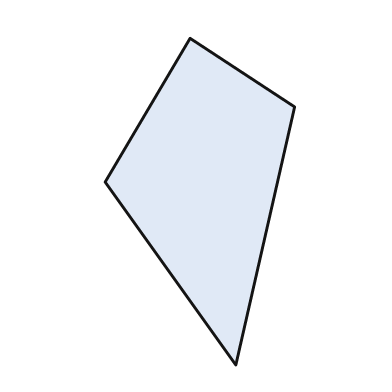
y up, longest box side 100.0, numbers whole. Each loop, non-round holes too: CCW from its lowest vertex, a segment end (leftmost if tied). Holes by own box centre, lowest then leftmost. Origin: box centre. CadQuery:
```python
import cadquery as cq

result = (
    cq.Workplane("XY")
    .moveTo(11.0, -50.0)
    .lineTo(29.0, 29.0)
    .lineTo(-3.0, 50.0)
    .lineTo(-29.0, 6.0)
    .close()
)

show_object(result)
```